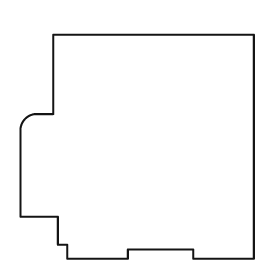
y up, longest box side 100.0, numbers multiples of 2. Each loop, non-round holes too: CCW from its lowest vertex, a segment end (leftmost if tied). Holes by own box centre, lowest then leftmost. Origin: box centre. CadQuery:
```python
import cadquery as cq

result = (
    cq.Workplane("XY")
    .moveTo(-30.0, -48.0)
    .lineTo(-4.0, -48.0)
    .lineTo(-4.0, -44.0)
    .lineTo(24.0, -44.0)
    .lineTo(24.0, -48.0)
    .lineTo(50.0, -48.0)
    .lineTo(50.0, 48.0)
    .lineTo(-36.0, 48.0)
    .lineTo(-36.0, 14.0)
    .lineTo(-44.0, 14.0)
    .threePointArc((-48.0, 12.0), (-50.0, 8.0))
    .lineTo(-50.0, -30.0)
    .lineTo(-34.0, -30.0)
    .lineTo(-34.0, -42.0)
    .lineTo(-30.0, -42.0)
    .close()
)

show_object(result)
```